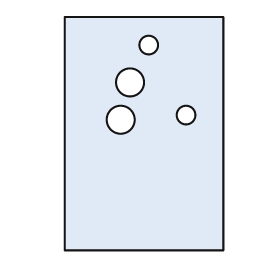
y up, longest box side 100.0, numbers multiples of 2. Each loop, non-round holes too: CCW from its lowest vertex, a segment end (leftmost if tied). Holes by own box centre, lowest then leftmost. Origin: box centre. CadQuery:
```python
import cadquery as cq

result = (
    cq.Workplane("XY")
    .moveTo(-34.0, -50.0)
    .lineTo(34.0, -50.0)
    .lineTo(34.0, 50.0)
    .lineTo(-34.0, 50.0)
    .close()
    .moveTo(-10.0, 6.0)
    .circle(6.0)
    .moveTo(18.0, 8.0)
    .circle(4.0)
    .moveTo(-6.0, 22.0)
    .circle(6.0)
    .moveTo(2.0, 38.0)
    .circle(4.0)
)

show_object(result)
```